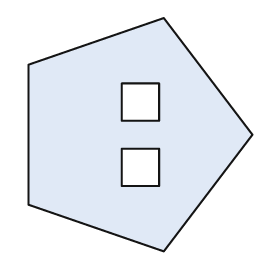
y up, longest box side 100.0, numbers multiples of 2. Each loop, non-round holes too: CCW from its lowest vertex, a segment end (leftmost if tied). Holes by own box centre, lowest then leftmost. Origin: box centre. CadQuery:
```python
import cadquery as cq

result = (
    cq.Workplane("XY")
    .moveTo(10.0, -50.0)
    .lineTo(48.0, 0.0)
    .lineTo(10.0, 50.0)
    .lineTo(-48.0, 30.0)
    .lineTo(-48.0, -30.0)
    .close()
    .moveTo(-8.0, -22.0)
    .lineTo(8.0, -22.0)
    .lineTo(8.0, -6.0)
    .lineTo(-8.0, -6.0)
    .close()
    .moveTo(-8.0, 6.0)
    .lineTo(8.0, 6.0)
    .lineTo(8.0, 22.0)
    .lineTo(-8.0, 22.0)
    .close()
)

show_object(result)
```